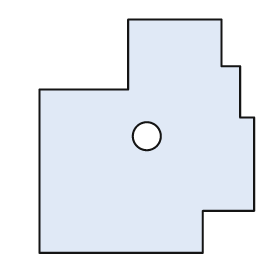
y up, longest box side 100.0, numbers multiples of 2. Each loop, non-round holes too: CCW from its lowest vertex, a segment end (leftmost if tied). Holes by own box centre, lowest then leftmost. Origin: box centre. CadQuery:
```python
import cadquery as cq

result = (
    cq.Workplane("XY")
    .moveTo(-46.0, -50.0)
    .lineTo(24.0, -50.0)
    .lineTo(24.0, -32.0)
    .lineTo(46.0, -32.0)
    .lineTo(46.0, 8.0)
    .lineTo(40.0, 8.0)
    .lineTo(40.0, 30.0)
    .lineTo(32.0, 30.0)
    .lineTo(32.0, 50.0)
    .lineTo(-8.0, 50.0)
    .lineTo(-8.0, 20.0)
    .lineTo(-46.0, 20.0)
    .close()
    .moveTo(0.0, 0.0)
    .circle(6.0)
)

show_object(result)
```